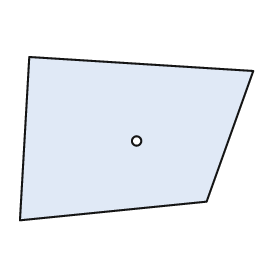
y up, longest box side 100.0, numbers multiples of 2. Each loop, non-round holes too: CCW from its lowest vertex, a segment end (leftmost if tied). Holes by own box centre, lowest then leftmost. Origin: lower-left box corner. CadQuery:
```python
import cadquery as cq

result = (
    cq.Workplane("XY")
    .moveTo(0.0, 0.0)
    .lineTo(80.0, 8.0)
    .lineTo(100.0, 64.0)
    .lineTo(4.0, 70.0)
    .close()
    .moveTo(50.0, 34.0)
    .circle(2.0)
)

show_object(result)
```